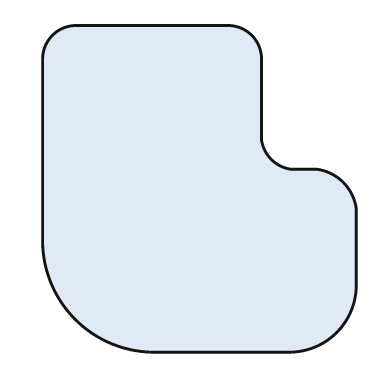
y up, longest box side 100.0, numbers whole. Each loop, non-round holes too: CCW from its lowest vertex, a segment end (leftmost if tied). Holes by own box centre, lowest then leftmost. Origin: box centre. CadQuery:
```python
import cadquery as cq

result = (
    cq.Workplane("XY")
    .moveTo(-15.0, -50.0)
    .lineTo(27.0, -50.0)
    .threePointArc((42.0, -44.0), (48.0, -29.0))
    .lineTo(48.0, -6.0)
    .threePointArc((44.0, 2.0), (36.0, 6.0))
    .lineTo(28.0, 6.0)
    .threePointArc((22.0, 9.0), (19.0, 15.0))
    .lineTo(19.0, 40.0)
    .threePointArc((16.0, 47.0), (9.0, 50.0))
    .lineTo(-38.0, 50.0)
    .threePointArc((-45.0, 47.0), (-48.0, 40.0))
    .lineTo(-48.0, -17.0)
    .threePointArc((-38.0, -40.0), (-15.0, -50.0))
    .close()
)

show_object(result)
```